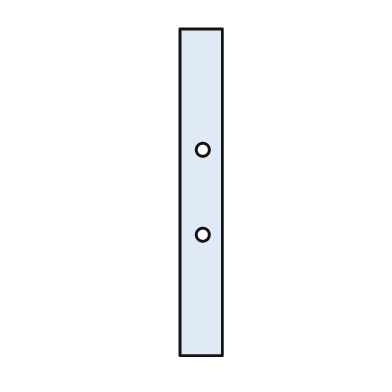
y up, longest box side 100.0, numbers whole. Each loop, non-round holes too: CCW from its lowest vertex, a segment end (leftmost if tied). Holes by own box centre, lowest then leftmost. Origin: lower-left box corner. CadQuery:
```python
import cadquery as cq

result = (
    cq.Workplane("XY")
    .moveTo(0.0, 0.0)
    .lineTo(13.0, 0.0)
    .lineTo(13.0, 100.0)
    .lineTo(0.0, 100.0)
    .close()
    .moveTo(7.0, 37.0)
    .circle(2.0)
    .moveTo(7.0, 63.0)
    .circle(2.0)
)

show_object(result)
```